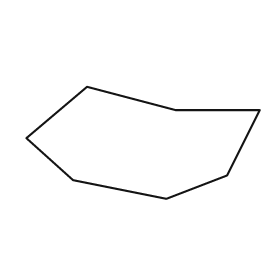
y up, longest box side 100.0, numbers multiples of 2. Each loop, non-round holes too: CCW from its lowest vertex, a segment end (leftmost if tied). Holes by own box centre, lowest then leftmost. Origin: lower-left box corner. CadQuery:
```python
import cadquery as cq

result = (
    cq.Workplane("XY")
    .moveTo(60.0, 0.0)
    .lineTo(86.0, 10.0)
    .lineTo(100.0, 38.0)
    .lineTo(64.0, 38.0)
    .lineTo(26.0, 48.0)
    .lineTo(0.0, 26.0)
    .lineTo(20.0, 8.0)
    .close()
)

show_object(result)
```